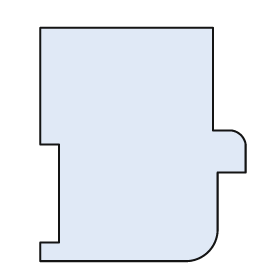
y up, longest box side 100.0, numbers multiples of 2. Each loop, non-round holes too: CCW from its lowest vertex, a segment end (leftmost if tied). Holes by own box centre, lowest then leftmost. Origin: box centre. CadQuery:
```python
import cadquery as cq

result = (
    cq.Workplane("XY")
    .moveTo(-44.0, -50.0)
    .lineTo(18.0, -50.0)
    .threePointArc((28.0, -46.0), (32.0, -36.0))
    .lineTo(32.0, -12.0)
    .lineTo(44.0, -12.0)
    .lineTo(44.0, 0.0)
    .threePointArc((42.0, 4.0), (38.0, 6.0))
    .lineTo(30.0, 6.0)
    .lineTo(30.0, 50.0)
    .lineTo(-44.0, 50.0)
    .lineTo(-44.0, 0.0)
    .lineTo(-36.0, 0.0)
    .lineTo(-36.0, -42.0)
    .lineTo(-44.0, -42.0)
    .close()
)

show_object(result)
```